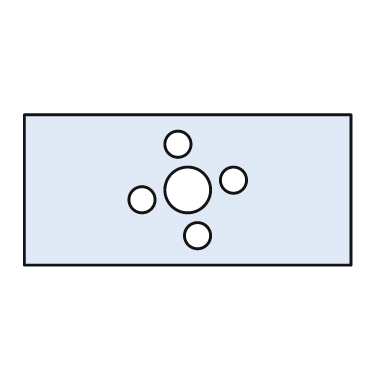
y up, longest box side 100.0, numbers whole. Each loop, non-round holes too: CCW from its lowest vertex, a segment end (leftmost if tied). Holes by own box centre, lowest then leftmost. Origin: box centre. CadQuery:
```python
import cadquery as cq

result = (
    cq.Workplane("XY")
    .moveTo(-50.0, -23.0)
    .lineTo(50.0, -23.0)
    .lineTo(50.0, 23.0)
    .lineTo(-50.0, 23.0)
    .close()
    .moveTo(3.0, -14.0)
    .circle(4.0)
    .moveTo(-14.0, -3.0)
    .circle(4.0)
    .moveTo(0.0, 0.0)
    .circle(7.0)
    .moveTo(14.0, 3.0)
    .circle(4.0)
    .moveTo(-3.0, 14.0)
    .circle(4.0)
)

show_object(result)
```